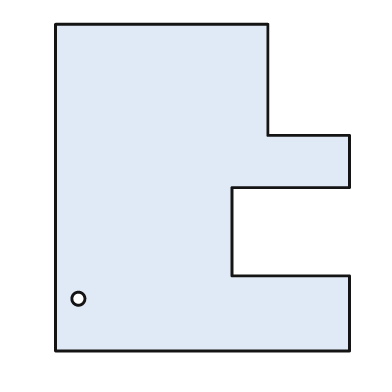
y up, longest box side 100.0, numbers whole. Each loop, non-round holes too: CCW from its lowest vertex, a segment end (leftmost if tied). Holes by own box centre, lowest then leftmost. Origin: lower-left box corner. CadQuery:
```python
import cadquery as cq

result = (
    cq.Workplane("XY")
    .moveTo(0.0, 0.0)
    .lineTo(90.0, 0.0)
    .lineTo(90.0, 23.0)
    .lineTo(54.0, 23.0)
    .lineTo(54.0, 50.0)
    .lineTo(90.0, 50.0)
    .lineTo(90.0, 66.0)
    .lineTo(65.0, 66.0)
    .lineTo(65.0, 100.0)
    .lineTo(0.0, 100.0)
    .close()
    .moveTo(7.0, 16.0)
    .circle(2.0)
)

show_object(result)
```